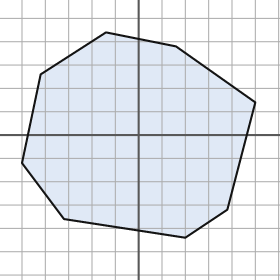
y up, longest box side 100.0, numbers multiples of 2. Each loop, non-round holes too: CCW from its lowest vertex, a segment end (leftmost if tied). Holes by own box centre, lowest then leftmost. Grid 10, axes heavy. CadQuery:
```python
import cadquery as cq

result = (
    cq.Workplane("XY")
    .moveTo(20.0, -44.0)
    .lineTo(38.0, -32.0)
    .lineTo(50.0, 14.0)
    .lineTo(16.0, 38.0)
    .lineTo(-14.0, 44.0)
    .lineTo(-42.0, 26.0)
    .lineTo(-50.0, -12.0)
    .lineTo(-32.0, -36.0)
    .close()
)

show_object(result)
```